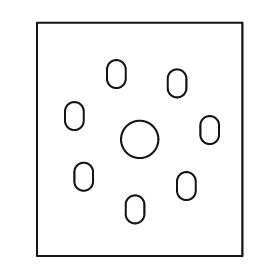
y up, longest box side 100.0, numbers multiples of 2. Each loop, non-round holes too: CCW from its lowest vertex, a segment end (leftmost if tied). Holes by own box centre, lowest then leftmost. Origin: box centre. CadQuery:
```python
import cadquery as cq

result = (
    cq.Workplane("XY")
    .moveTo(-44.0, -50.0)
    .lineTo(44.0, -50.0)
    .lineTo(44.0, 50.0)
    .lineTo(-44.0, 50.0)
    .close()
    .moveTo(-6.0, -32.0)
    .threePointArc((-2.0, -36.0), (2.0, -32.0))
    .lineTo(2.0, -28.0)
    .threePointArc((-2.0, -24.0), (-6.0, -28.0))
    .close()
    .moveTo(16.0, -22.0)
    .threePointArc((20.0, -26.0), (24.0, -22.0))
    .lineTo(24.0, -18.0)
    .threePointArc((20.0, -14.0), (16.0, -18.0))
    .close()
    .moveTo(-28.0, -18.0)
    .threePointArc((-24.0, -22.0), (-20.0, -18.0))
    .lineTo(-20.0, -14.0)
    .threePointArc((-24.0, -10.0), (-28.0, -14.0))
    .close()
    .moveTo(0.0, 0.0)
    .circle(8.0)
    .moveTo(26.0, 2.0)
    .threePointArc((30.0, -2.0), (34.0, 2.0))
    .lineTo(34.0, 6.0)
    .threePointArc((30.0, 10.0), (26.0, 6.0))
    .close()
    .moveTo(-32.0, 8.0)
    .threePointArc((-28.0, 4.0), (-24.0, 8.0))
    .lineTo(-24.0, 12.0)
    .threePointArc((-28.0, 16.0), (-32.0, 12.0))
    .close()
    .moveTo(12.0, 22.0)
    .threePointArc((16.0, 18.0), (20.0, 22.0))
    .lineTo(20.0, 26.0)
    .threePointArc((16.0, 30.0), (12.0, 26.0))
    .close()
    .moveTo(-14.0, 26.0)
    .threePointArc((-10.0, 22.0), (-6.0, 26.0))
    .lineTo(-6.0, 30.0)
    .threePointArc((-10.0, 34.0), (-14.0, 30.0))
    .close()
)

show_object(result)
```